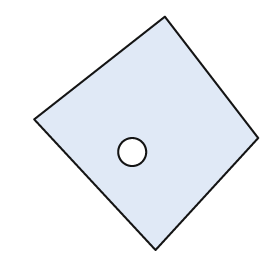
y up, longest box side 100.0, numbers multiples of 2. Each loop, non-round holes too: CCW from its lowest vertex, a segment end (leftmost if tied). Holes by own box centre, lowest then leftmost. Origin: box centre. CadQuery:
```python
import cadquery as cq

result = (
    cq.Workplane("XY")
    .moveTo(4.0, -50.0)
    .lineTo(48.0, -2.0)
    .lineTo(8.0, 50.0)
    .lineTo(-48.0, 6.0)
    .close()
    .moveTo(-6.0, -8.0)
    .circle(6.0)
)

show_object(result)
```